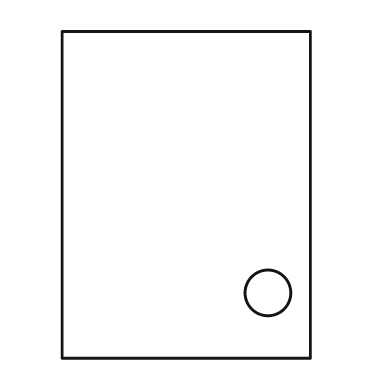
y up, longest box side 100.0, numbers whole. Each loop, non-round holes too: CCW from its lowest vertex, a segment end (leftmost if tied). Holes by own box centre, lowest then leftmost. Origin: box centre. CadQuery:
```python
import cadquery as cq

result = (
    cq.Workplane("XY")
    .moveTo(-38.0, -50.0)
    .lineTo(38.0, -50.0)
    .lineTo(38.0, 50.0)
    .lineTo(-38.0, 50.0)
    .close()
    .moveTo(25.0, -30.0)
    .circle(7.0)
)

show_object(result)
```